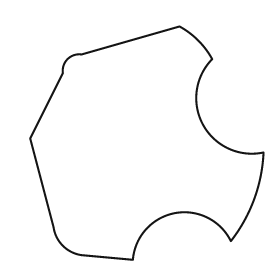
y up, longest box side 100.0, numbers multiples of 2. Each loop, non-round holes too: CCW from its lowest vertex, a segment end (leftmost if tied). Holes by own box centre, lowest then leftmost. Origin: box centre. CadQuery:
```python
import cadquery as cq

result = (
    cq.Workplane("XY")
    .moveTo(-6.0, -50.0)
    .threePointArc((12.0, -30.0), (36.0, -42.0))
    .threePointArc((46.0, -24.0), (50.0, -4.0))
    .threePointArc((24.0, 8.0), (28.0, 36.0))
    .threePointArc((22.0, 44.0), (14.0, 50.0))
    .lineTo(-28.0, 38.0)
    .threePointArc((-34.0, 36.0), (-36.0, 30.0))
    .lineTo(-50.0, 2.0)
    .lineTo(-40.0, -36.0)
    .threePointArc((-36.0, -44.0), (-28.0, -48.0))
    .close()
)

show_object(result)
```